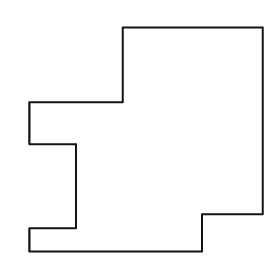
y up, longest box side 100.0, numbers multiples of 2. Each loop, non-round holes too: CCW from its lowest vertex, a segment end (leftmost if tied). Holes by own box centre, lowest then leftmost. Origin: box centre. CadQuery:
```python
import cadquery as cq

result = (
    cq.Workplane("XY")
    .moveTo(-50.0, -48.0)
    .lineTo(24.0, -48.0)
    .lineTo(24.0, -32.0)
    .lineTo(50.0, -32.0)
    .lineTo(50.0, 48.0)
    .lineTo(-10.0, 48.0)
    .lineTo(-10.0, 16.0)
    .lineTo(-50.0, 16.0)
    .lineTo(-50.0, -2.0)
    .lineTo(-30.0, -2.0)
    .lineTo(-30.0, -38.0)
    .lineTo(-50.0, -38.0)
    .close()
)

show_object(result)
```